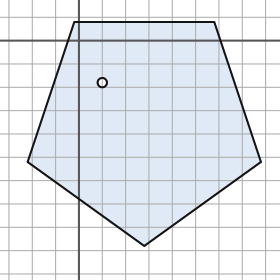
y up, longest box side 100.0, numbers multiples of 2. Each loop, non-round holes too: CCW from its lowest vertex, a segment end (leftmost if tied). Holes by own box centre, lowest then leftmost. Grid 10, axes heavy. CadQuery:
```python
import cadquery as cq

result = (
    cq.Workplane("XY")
    .moveTo(28.0, -88.0)
    .lineTo(78.0, -52.0)
    .lineTo(58.0, 8.0)
    .lineTo(-2.0, 8.0)
    .lineTo(-22.0, -52.0)
    .close()
    .moveTo(10.0, -18.0)
    .circle(2.0)
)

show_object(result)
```